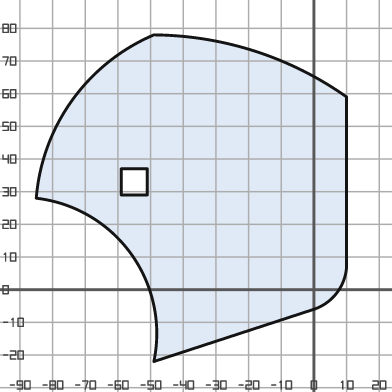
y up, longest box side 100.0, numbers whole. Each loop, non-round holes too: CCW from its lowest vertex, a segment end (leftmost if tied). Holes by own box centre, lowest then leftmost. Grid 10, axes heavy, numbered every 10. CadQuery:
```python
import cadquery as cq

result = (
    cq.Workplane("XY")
    .moveTo(-49.0, -22.0)
    .lineTo(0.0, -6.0)
    .threePointArc((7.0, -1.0), (10.0, 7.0))
    .lineTo(10.0, 59.0)
    .threePointArc((-18.0, 73.0), (-49.0, 78.0))
    .threePointArc((-74.0, 58.0), (-85.0, 28.0))
    .threePointArc((-56.0, 11.0), (-49.0, -22.0))
    .close()
    .moveTo(-59.0, 29.0)
    .lineTo(-51.0, 29.0)
    .lineTo(-51.0, 37.0)
    .lineTo(-59.0, 37.0)
    .close()
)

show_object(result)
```